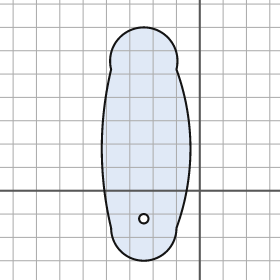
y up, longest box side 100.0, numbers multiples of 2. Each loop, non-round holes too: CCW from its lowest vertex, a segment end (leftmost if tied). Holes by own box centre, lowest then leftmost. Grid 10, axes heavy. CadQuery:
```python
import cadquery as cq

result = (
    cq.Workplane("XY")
    .moveTo(-38.0, -16.0)
    .threePointArc((-24.0, -30.0), (-10.0, -16.0))
    .threePointArc((-4.0, 18.0), (-10.0, 52.0))
    .threePointArc((-24.0, 70.0), (-38.0, 52.0))
    .threePointArc((-42.0, 18.0), (-38.0, -16.0))
    .close()
    .moveTo(-24.0, -12.0)
    .circle(2.0)
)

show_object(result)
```